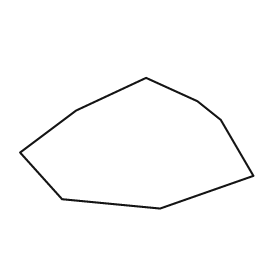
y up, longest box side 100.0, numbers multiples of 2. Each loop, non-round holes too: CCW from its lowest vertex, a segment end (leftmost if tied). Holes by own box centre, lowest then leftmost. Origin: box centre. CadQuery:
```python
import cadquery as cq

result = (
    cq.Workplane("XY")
    .moveTo(10.0, -28.0)
    .lineTo(50.0, -14.0)
    .lineTo(36.0, 10.0)
    .lineTo(26.0, 18.0)
    .lineTo(4.0, 28.0)
    .lineTo(-26.0, 14.0)
    .lineTo(-50.0, -4.0)
    .lineTo(-32.0, -24.0)
    .close()
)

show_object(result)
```